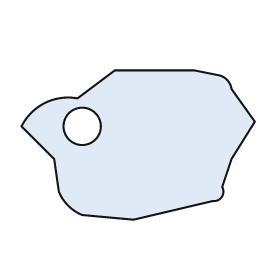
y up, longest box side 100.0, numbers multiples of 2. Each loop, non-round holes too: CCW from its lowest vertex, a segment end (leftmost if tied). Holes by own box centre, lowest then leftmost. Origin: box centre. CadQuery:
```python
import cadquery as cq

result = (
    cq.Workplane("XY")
    .moveTo(-2.0, -32.0)
    .lineTo(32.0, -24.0)
    .threePointArc((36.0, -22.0), (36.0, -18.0))
    .lineTo(40.0, -6.0)
    .lineTo(50.0, 10.0)
    .lineTo(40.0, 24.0)
    .threePointArc((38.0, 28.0), (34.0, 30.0))
    .lineTo(24.0, 32.0)
    .lineTo(-10.0, 32.0)
    .lineTo(-26.0, 20.0)
    .threePointArc((-40.0, 18.0), (-50.0, 8.0))
    .lineTo(-36.0, -6.0)
    .lineTo(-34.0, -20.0)
    .threePointArc((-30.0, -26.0), (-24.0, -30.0))
    .close()
    .moveTo(-24.0, 8.0)
    .circle(8.0)
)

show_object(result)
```